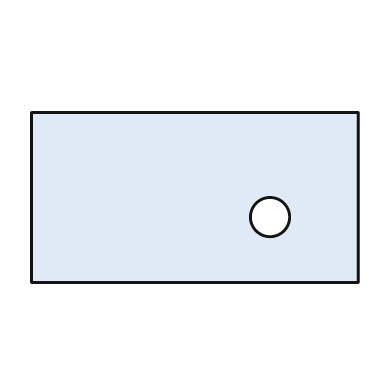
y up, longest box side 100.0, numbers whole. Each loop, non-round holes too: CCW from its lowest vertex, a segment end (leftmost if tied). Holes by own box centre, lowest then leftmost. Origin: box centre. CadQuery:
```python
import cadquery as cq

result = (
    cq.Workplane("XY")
    .moveTo(-50.0, -26.0)
    .lineTo(50.0, -26.0)
    .lineTo(50.0, 26.0)
    .lineTo(-50.0, 26.0)
    .close()
    .moveTo(23.0, -6.0)
    .circle(6.0)
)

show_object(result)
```